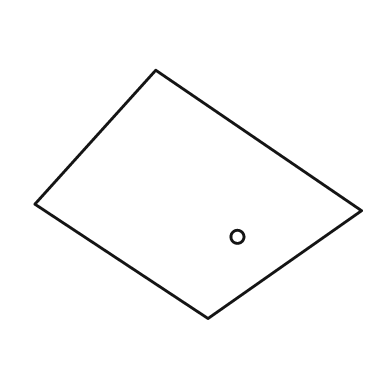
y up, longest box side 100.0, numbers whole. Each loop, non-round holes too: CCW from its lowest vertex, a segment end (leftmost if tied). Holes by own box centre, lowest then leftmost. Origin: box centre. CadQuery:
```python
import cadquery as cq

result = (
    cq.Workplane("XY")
    .moveTo(3.0, -38.0)
    .lineTo(50.0, -5.0)
    .lineTo(-13.0, 38.0)
    .lineTo(-50.0, -3.0)
    .close()
    .moveTo(12.0, -13.0)
    .circle(2.0)
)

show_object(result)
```